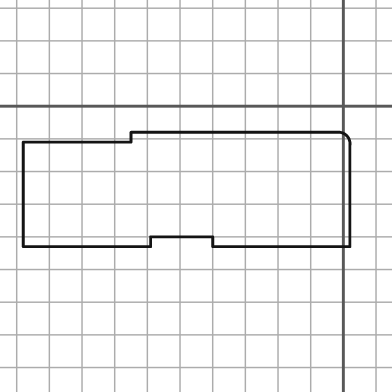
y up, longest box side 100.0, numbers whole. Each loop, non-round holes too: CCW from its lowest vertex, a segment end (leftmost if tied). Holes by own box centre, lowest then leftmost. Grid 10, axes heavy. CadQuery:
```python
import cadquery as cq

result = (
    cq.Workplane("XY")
    .moveTo(-98.0, -43.0)
    .lineTo(-59.0, -43.0)
    .lineTo(-59.0, -40.0)
    .lineTo(-40.0, -40.0)
    .lineTo(-40.0, -43.0)
    .lineTo(2.0, -43.0)
    .lineTo(2.0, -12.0)
    .threePointArc((1.0, -9.0), (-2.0, -8.0))
    .lineTo(-65.0, -8.0)
    .lineTo(-65.0, -11.0)
    .lineTo(-98.0, -11.0)
    .close()
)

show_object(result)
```